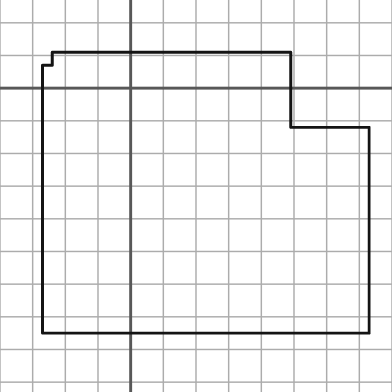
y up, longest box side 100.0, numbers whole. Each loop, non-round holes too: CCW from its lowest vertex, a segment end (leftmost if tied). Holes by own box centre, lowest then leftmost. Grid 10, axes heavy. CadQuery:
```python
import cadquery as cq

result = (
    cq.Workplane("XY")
    .moveTo(-27.0, -75.0)
    .lineTo(73.0, -75.0)
    .lineTo(73.0, -12.0)
    .lineTo(49.0, -12.0)
    .lineTo(49.0, 11.0)
    .lineTo(-24.0, 11.0)
    .lineTo(-24.0, 7.0)
    .lineTo(-27.0, 7.0)
    .close()
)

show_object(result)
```